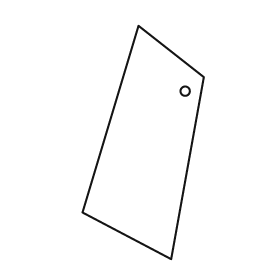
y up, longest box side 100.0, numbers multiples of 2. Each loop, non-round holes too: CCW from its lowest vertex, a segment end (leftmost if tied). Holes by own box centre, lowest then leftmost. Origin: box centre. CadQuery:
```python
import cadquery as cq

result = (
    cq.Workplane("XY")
    .moveTo(12.0, -50.0)
    .lineTo(26.0, 28.0)
    .lineTo(-2.0, 50.0)
    .lineTo(-26.0, -30.0)
    .close()
    .moveTo(18.0, 22.0)
    .circle(2.0)
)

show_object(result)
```